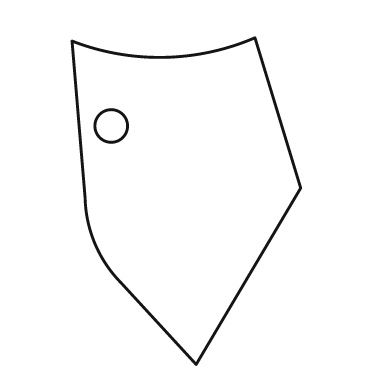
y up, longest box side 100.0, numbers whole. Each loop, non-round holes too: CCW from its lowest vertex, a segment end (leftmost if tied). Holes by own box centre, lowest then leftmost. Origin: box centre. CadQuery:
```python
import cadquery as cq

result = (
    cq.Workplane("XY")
    .moveTo(3.0, -50.0)
    .lineTo(35.0, 4.0)
    .lineTo(21.0, 50.0)
    .threePointArc((-7.0, 44.0), (-35.0, 49.0))
    .lineTo(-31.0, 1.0)
    .threePointArc((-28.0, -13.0), (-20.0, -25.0))
    .close()
    .moveTo(-23.0, 23.0)
    .circle(5.0)
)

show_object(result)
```